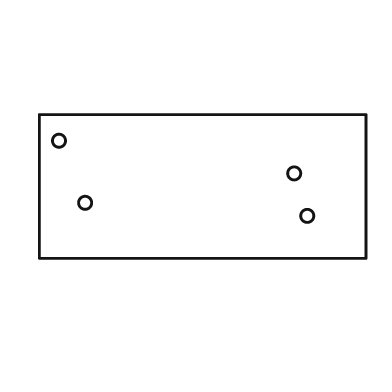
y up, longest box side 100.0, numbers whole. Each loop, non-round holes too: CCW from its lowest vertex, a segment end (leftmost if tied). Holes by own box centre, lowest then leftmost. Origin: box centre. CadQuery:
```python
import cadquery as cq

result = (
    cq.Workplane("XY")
    .moveTo(-50.0, -22.0)
    .lineTo(50.0, -22.0)
    .lineTo(50.0, 22.0)
    .lineTo(-50.0, 22.0)
    .close()
    .moveTo(32.0, -9.0)
    .circle(2.0)
    .moveTo(-36.0, -5.0)
    .circle(2.0)
    .moveTo(28.0, 4.0)
    .circle(2.0)
    .moveTo(-44.0, 14.0)
    .circle(2.0)
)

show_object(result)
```